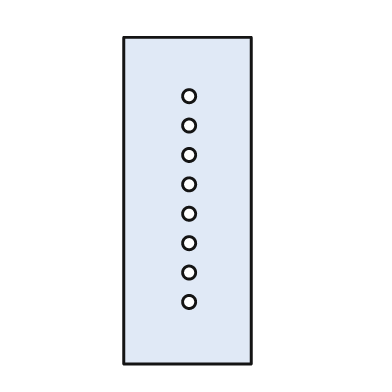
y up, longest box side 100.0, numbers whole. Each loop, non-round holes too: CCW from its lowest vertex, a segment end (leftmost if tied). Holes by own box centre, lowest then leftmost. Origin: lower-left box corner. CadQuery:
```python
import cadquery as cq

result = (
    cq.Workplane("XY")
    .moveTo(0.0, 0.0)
    .lineTo(39.0, 0.0)
    .lineTo(39.0, 100.0)
    .lineTo(0.0, 100.0)
    .close()
    .moveTo(20.0, 19.0)
    .circle(2.0)
    .moveTo(20.0, 28.0)
    .circle(2.0)
    .moveTo(20.0, 37.0)
    .circle(2.0)
    .moveTo(20.0, 46.0)
    .circle(2.0)
    .moveTo(20.0, 55.0)
    .circle(2.0)
    .moveTo(20.0, 64.0)
    .circle(2.0)
    .moveTo(20.0, 73.0)
    .circle(2.0)
    .moveTo(20.0, 82.0)
    .circle(2.0)
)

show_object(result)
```